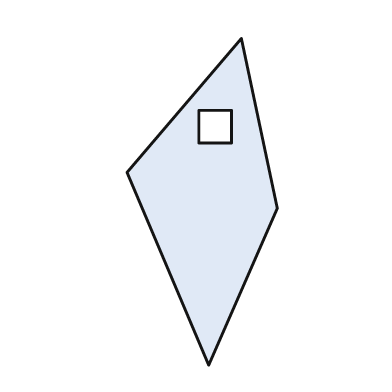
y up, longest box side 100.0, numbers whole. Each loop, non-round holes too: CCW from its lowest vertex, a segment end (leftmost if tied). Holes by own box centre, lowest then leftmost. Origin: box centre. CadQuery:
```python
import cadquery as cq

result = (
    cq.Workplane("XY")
    .moveTo(2.0, -50.0)
    .lineTo(23.0, -2.0)
    .lineTo(12.0, 50.0)
    .lineTo(-23.0, 9.0)
    .close()
    .moveTo(-1.0, 18.0)
    .lineTo(9.0, 18.0)
    .lineTo(9.0, 28.0)
    .lineTo(-1.0, 28.0)
    .close()
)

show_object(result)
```